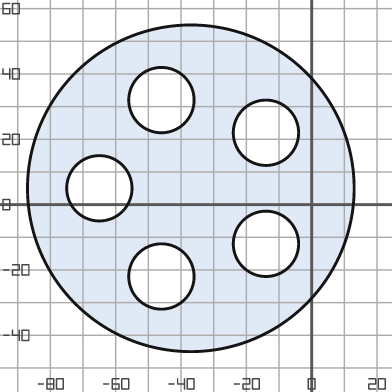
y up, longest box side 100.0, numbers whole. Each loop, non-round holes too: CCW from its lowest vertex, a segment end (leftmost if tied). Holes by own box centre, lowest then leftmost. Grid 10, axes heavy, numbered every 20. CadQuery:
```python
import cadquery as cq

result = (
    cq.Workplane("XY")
    .moveTo(-37.0, 5.0)
    .circle(50.0)
    .moveTo(-46.0, -22.0)
    .circle(10.0)
    .moveTo(-14.0, -12.0)
    .circle(10.0)
    .moveTo(-65.0, 5.0)
    .circle(10.0)
    .moveTo(-14.0, 22.0)
    .circle(10.0)
    .moveTo(-46.0, 32.0)
    .circle(10.0)
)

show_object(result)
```